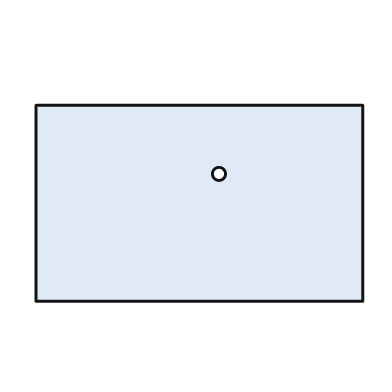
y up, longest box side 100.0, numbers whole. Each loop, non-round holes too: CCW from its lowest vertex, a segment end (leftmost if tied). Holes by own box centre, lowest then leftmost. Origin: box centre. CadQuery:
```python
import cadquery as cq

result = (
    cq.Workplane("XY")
    .moveTo(-50.0, -30.0)
    .lineTo(50.0, -30.0)
    .lineTo(50.0, 30.0)
    .lineTo(-50.0, 30.0)
    .close()
    .moveTo(6.0, 9.0)
    .circle(2.0)
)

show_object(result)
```